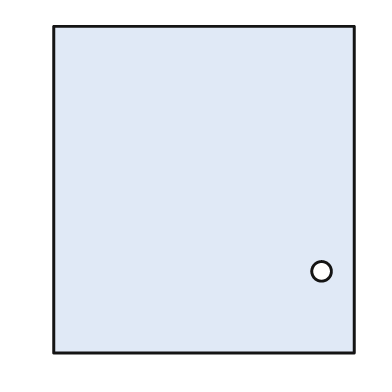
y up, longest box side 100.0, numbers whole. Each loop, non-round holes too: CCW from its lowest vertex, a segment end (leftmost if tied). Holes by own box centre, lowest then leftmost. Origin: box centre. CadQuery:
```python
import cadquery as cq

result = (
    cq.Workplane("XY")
    .moveTo(-46.0, -50.0)
    .lineTo(46.0, -50.0)
    .lineTo(46.0, 50.0)
    .lineTo(-46.0, 50.0)
    .close()
    .moveTo(36.0, -25.0)
    .circle(3.0)
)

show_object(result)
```